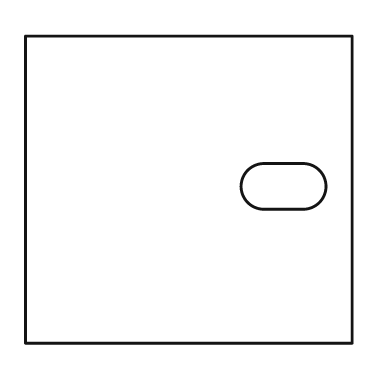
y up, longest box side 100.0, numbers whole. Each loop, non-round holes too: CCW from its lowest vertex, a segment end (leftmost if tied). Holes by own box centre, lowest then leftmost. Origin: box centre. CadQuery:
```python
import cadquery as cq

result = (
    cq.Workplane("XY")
    .moveTo(-50.0, -47.0)
    .lineTo(50.0, -47.0)
    .lineTo(50.0, 47.0)
    .lineTo(-50.0, 47.0)
    .close()
    .moveTo(23.0, -6.0)
    .lineTo(35.0, -6.0)
    .threePointArc((42.0, 1.0), (35.0, 8.0))
    .lineTo(23.0, 8.0)
    .threePointArc((16.0, 1.0), (23.0, -6.0))
    .close()
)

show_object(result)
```